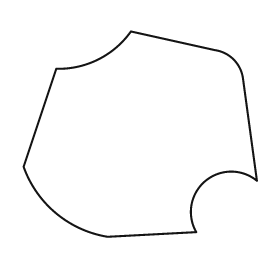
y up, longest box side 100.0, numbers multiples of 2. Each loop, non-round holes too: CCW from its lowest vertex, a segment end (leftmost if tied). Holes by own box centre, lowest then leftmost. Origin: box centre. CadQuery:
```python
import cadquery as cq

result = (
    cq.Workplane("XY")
    .moveTo(-14.0, -44.0)
    .lineTo(24.0, -42.0)
    .threePointArc((28.0, -20.0), (50.0, -20.0))
    .lineTo(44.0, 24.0)
    .threePointArc((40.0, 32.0), (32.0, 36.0))
    .lineTo(-4.0, 44.0)
    .threePointArc((-18.0, 32.0), (-36.0, 28.0))
    .lineTo(-50.0, -14.0)
    .threePointArc((-36.0, -34.0), (-14.0, -44.0))
    .close()
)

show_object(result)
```